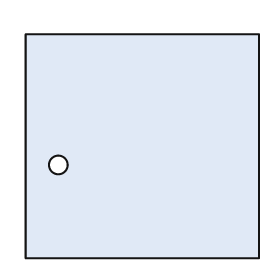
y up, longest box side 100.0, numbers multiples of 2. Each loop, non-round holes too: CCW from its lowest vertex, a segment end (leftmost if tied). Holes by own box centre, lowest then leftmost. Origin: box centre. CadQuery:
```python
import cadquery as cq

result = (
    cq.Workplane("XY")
    .moveTo(-50.0, -48.0)
    .lineTo(50.0, -48.0)
    .lineTo(50.0, 48.0)
    .lineTo(-50.0, 48.0)
    .close()
    .moveTo(-36.0, -8.0)
    .circle(4.0)
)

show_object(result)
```